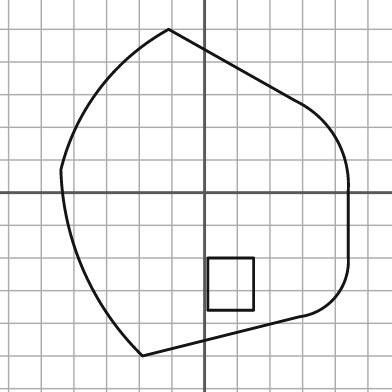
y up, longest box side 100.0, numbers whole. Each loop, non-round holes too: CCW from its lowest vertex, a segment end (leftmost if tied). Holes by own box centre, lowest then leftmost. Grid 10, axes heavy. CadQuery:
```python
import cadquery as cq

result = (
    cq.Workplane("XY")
    .moveTo(-19.0, -50.0)
    .lineTo(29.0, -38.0)
    .threePointArc((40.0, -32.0), (44.0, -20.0))
    .lineTo(44.0, 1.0)
    .threePointArc((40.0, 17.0), (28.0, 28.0))
    .lineTo(-11.0, 50.0)
    .threePointArc((-32.0, 32.0), (-44.0, 7.0))
    .threePointArc((-37.0, -24.0), (-19.0, -50.0))
    .close()
    .moveTo(1.0, -36.0)
    .lineTo(15.0, -36.0)
    .lineTo(15.0, -20.0)
    .lineTo(1.0, -20.0)
    .close()
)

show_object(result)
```